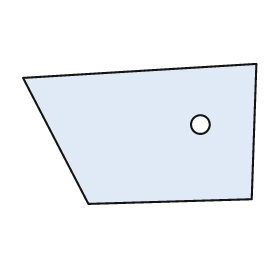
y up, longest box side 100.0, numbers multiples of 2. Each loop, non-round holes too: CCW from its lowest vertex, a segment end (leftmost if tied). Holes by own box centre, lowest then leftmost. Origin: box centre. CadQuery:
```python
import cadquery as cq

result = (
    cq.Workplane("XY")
    .moveTo(-22.0, -30.0)
    .lineTo(48.0, -28.0)
    .lineTo(50.0, 30.0)
    .lineTo(-50.0, 24.0)
    .close()
    .moveTo(26.0, 4.0)
    .circle(4.0)
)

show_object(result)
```